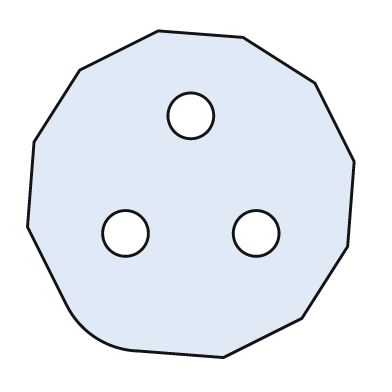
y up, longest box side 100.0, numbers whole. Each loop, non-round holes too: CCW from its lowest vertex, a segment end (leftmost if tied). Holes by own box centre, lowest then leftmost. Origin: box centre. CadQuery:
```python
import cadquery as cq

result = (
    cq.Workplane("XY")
    .moveTo(10.0, -50.0)
    .lineTo(34.0, -38.0)
    .lineTo(48.0, -16.0)
    .lineTo(50.0, 10.0)
    .lineTo(38.0, 34.0)
    .lineTo(16.0, 48.0)
    .lineTo(-10.0, 50.0)
    .lineTo(-34.0, 38.0)
    .lineTo(-48.0, 16.0)
    .lineTo(-50.0, -10.0)
    .lineTo(-38.0, -34.0)
    .threePointArc((-29.0, -44.0), (-16.0, -48.0))
    .close()
    .moveTo(-20.0, -12.0)
    .circle(7.0)
    .moveTo(20.0, -12.0)
    .circle(7.0)
    .moveTo(0.0, 24.0)
    .circle(7.0)
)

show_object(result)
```